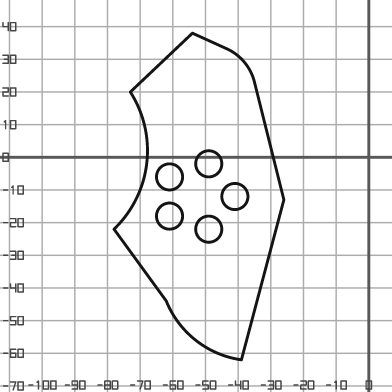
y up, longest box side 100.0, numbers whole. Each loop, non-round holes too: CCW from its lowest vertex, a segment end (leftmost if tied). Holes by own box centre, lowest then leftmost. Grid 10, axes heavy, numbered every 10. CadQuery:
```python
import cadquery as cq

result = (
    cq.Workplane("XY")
    .moveTo(-39.0, -62.0)
    .lineTo(-26.0, -13.0)
    .lineTo(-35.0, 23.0)
    .threePointArc((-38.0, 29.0), (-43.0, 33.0))
    .lineTo(-54.0, 38.0)
    .lineTo(-73.0, 20.0)
    .threePointArc((-68.0, -2.0), (-78.0, -22.0))
    .lineTo(-62.0, -44.0)
    .threePointArc((-53.0, -56.0), (-39.0, -62.0))
    .close()
    .moveTo(-49.0, -22.0)
    .circle(4.0)
    .moveTo(-61.0, -18.0)
    .circle(4.0)
    .moveTo(-41.0, -12.0)
    .circle(4.0)
    .moveTo(-61.0, -6.0)
    .circle(4.0)
    .moveTo(-49.0, -2.0)
    .circle(4.0)
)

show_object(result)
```